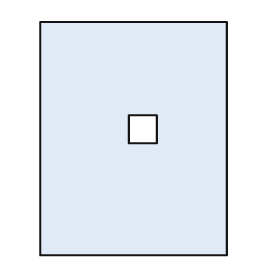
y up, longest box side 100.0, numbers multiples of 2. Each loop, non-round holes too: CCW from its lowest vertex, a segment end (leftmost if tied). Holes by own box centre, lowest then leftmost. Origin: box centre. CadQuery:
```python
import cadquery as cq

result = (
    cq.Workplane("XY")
    .moveTo(-40.0, -50.0)
    .lineTo(40.0, -50.0)
    .lineTo(40.0, 50.0)
    .lineTo(-40.0, 50.0)
    .close()
    .moveTo(-2.0, -2.0)
    .lineTo(10.0, -2.0)
    .lineTo(10.0, 10.0)
    .lineTo(-2.0, 10.0)
    .close()
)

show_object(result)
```